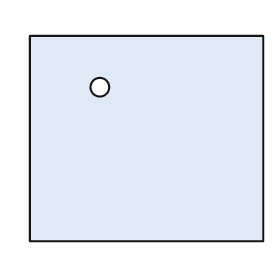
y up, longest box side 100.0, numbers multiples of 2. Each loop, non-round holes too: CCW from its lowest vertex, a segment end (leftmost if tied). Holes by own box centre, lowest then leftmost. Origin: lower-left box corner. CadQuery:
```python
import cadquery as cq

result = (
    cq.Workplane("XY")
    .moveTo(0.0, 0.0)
    .lineTo(100.0, 0.0)
    .lineTo(100.0, 88.0)
    .lineTo(0.0, 88.0)
    .close()
    .moveTo(30.0, 66.0)
    .circle(4.0)
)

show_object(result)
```